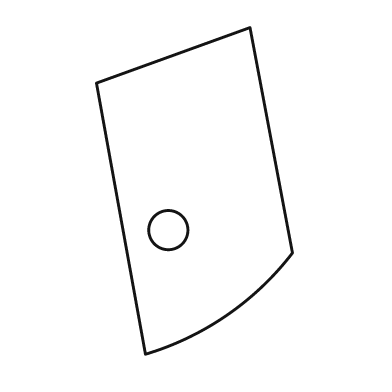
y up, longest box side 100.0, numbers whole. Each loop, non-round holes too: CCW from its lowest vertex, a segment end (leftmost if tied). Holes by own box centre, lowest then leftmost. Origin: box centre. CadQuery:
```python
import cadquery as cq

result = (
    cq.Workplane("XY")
    .moveTo(-15.0, -50.0)
    .threePointArc((10.0, -38.0), (30.0, -19.0))
    .lineTo(17.0, 50.0)
    .lineTo(-30.0, 33.0)
    .close()
    .moveTo(-8.0, -12.0)
    .circle(6.0)
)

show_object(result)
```